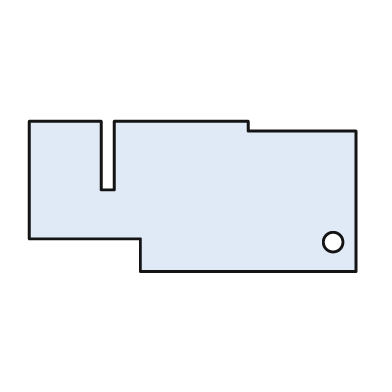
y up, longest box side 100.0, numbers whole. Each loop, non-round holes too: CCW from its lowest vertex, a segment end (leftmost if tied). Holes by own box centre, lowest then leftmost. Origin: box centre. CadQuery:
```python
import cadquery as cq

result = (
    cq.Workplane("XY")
    .moveTo(-16.0, -23.0)
    .lineTo(50.0, -23.0)
    .lineTo(50.0, 20.0)
    .lineTo(17.0, 20.0)
    .lineTo(17.0, 23.0)
    .lineTo(-24.0, 23.0)
    .lineTo(-24.0, 2.0)
    .lineTo(-28.0, 2.0)
    .lineTo(-28.0, 23.0)
    .lineTo(-50.0, 23.0)
    .lineTo(-50.0, -13.0)
    .lineTo(-16.0, -13.0)
    .close()
    .moveTo(43.0, -14.0)
    .circle(3.0)
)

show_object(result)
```